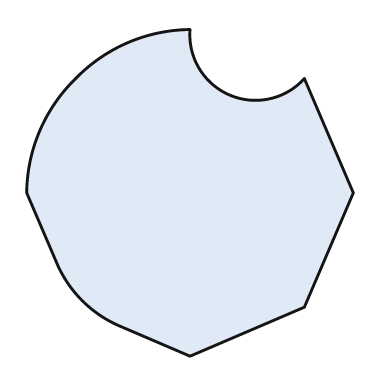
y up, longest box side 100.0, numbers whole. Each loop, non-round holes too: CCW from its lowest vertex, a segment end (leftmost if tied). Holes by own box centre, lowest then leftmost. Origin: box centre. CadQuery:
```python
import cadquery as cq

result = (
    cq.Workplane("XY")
    .moveTo(0.0, -50.0)
    .lineTo(35.0, -35.0)
    .lineTo(50.0, 0.0)
    .lineTo(35.0, 35.0)
    .threePointArc((12.0, 30.0), (0.0, 50.0))
    .threePointArc((-19.0, 46.0), (-35.0, 35.0))
    .threePointArc((-46.0, 19.0), (-50.0, 0.0))
    .lineTo(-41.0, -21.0)
    .threePointArc((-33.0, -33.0), (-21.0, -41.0))
    .close()
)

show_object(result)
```